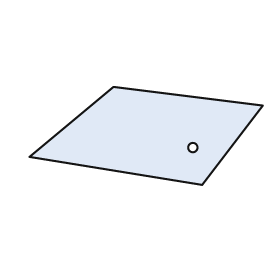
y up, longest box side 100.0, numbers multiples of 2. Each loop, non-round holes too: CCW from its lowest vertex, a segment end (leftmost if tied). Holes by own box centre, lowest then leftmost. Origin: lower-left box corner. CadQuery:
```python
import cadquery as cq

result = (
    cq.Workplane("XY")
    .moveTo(74.0, 0.0)
    .lineTo(100.0, 34.0)
    .lineTo(36.0, 42.0)
    .lineTo(0.0, 12.0)
    .close()
    .moveTo(70.0, 16.0)
    .circle(2.0)
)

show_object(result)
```